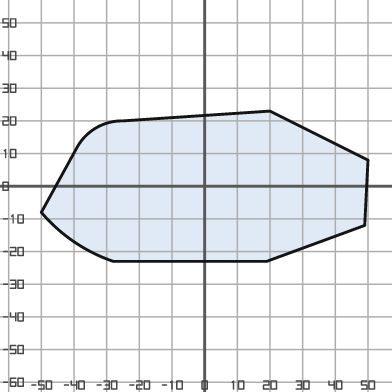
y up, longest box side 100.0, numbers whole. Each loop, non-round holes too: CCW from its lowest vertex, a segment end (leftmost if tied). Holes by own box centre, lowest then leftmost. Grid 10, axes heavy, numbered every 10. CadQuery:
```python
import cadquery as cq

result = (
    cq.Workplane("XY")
    .moveTo(-28.0, -23.0)
    .lineTo(19.0, -23.0)
    .lineTo(49.0, -12.0)
    .lineTo(50.0, 8.0)
    .lineTo(20.0, 23.0)
    .lineTo(-25.0, 20.0)
    .threePointArc((-33.0, 18.0), (-39.0, 12.0))
    .lineTo(-50.0, -8.0)
    .threePointArc((-40.0, -17.0), (-28.0, -23.0))
    .close()
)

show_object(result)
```